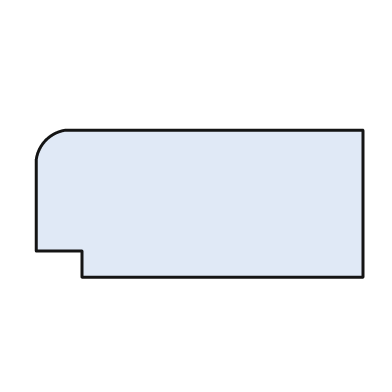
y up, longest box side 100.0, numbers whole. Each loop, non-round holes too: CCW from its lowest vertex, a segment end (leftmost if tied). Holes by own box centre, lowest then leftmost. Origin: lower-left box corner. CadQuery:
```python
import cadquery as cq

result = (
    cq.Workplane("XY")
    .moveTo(14.0, 0.0)
    .lineTo(100.0, 0.0)
    .lineTo(100.0, 45.0)
    .lineTo(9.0, 45.0)
    .threePointArc((3.0, 42.0), (0.0, 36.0))
    .lineTo(0.0, 8.0)
    .lineTo(14.0, 8.0)
    .close()
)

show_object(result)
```